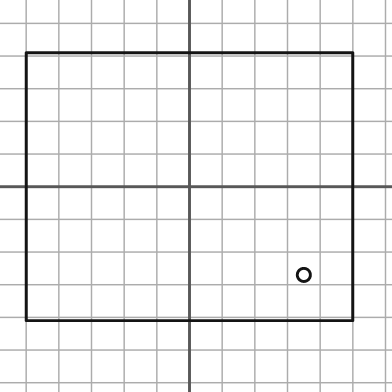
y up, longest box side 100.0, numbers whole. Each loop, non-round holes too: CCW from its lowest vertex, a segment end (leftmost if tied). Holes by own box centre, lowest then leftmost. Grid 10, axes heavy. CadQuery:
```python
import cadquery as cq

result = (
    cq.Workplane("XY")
    .moveTo(-50.0, -41.0)
    .lineTo(50.0, -41.0)
    .lineTo(50.0, 41.0)
    .lineTo(-50.0, 41.0)
    .close()
    .moveTo(35.0, -27.0)
    .circle(2.0)
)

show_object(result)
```